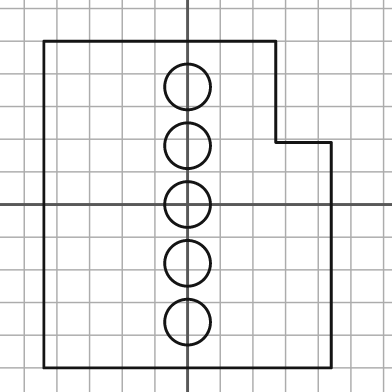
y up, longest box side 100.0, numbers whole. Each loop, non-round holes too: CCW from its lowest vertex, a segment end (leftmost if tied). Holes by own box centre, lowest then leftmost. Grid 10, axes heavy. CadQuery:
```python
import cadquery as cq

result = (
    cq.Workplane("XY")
    .moveTo(-44.0, -50.0)
    .lineTo(44.0, -50.0)
    .lineTo(44.0, 19.0)
    .lineTo(27.0, 19.0)
    .lineTo(27.0, 50.0)
    .lineTo(-44.0, 50.0)
    .close()
    .moveTo(0.0, -36.0)
    .circle(7.0)
    .moveTo(0.0, -18.0)
    .circle(7.0)
    .moveTo(0.0, 0.0)
    .circle(7.0)
    .moveTo(0.0, 18.0)
    .circle(7.0)
    .moveTo(0.0, 36.0)
    .circle(7.0)
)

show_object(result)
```